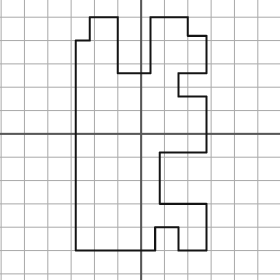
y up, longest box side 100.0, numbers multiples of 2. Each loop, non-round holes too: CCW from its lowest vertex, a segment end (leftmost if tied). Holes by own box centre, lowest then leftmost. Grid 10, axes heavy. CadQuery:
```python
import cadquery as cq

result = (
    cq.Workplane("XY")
    .moveTo(-28.0, -50.0)
    .lineTo(6.0, -50.0)
    .lineTo(6.0, -40.0)
    .lineTo(16.0, -40.0)
    .lineTo(16.0, -50.0)
    .lineTo(28.0, -50.0)
    .lineTo(28.0, -30.0)
    .lineTo(8.0, -30.0)
    .lineTo(8.0, -8.0)
    .lineTo(28.0, -8.0)
    .lineTo(28.0, 16.0)
    .lineTo(16.0, 16.0)
    .lineTo(16.0, 26.0)
    .lineTo(28.0, 26.0)
    .lineTo(28.0, 42.0)
    .lineTo(20.0, 42.0)
    .lineTo(20.0, 50.0)
    .lineTo(4.0, 50.0)
    .lineTo(4.0, 26.0)
    .lineTo(-10.0, 26.0)
    .lineTo(-10.0, 50.0)
    .lineTo(-22.0, 50.0)
    .lineTo(-22.0, 40.0)
    .lineTo(-28.0, 40.0)
    .close()
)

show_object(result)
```